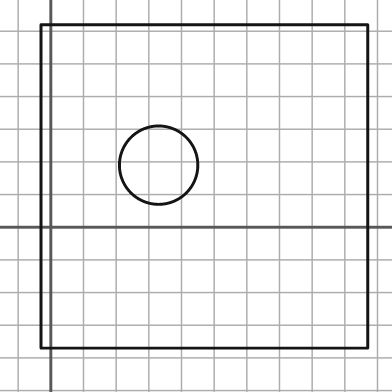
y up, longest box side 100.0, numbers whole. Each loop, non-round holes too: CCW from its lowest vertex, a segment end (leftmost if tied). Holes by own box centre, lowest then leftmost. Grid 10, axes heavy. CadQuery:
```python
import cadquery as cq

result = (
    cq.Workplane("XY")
    .moveTo(-3.0, -37.0)
    .lineTo(97.0, -37.0)
    .lineTo(97.0, 62.0)
    .lineTo(-3.0, 62.0)
    .close()
    .moveTo(33.0, 19.0)
    .circle(12.0)
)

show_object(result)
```